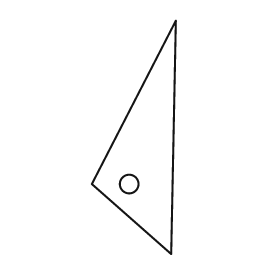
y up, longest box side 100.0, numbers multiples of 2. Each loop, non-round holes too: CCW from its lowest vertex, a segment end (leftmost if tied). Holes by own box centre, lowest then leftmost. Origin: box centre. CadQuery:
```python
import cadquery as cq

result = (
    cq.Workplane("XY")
    .moveTo(16.0, -50.0)
    .lineTo(18.0, 50.0)
    .lineTo(-18.0, -20.0)
    .close()
    .moveTo(-2.0, -20.0)
    .circle(4.0)
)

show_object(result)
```